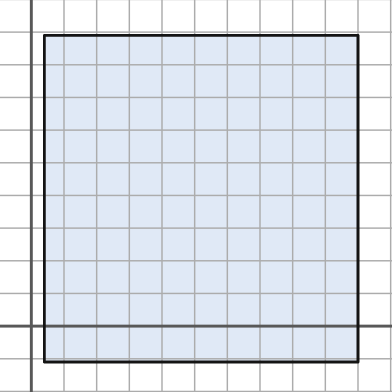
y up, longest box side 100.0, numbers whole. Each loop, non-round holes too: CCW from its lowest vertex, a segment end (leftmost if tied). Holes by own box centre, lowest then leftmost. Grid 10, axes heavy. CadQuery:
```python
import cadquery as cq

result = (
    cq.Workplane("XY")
    .moveTo(4.0, -11.0)
    .lineTo(100.0, -11.0)
    .lineTo(100.0, 89.0)
    .lineTo(4.0, 89.0)
    .close()
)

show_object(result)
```